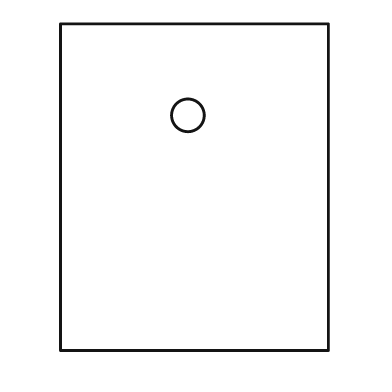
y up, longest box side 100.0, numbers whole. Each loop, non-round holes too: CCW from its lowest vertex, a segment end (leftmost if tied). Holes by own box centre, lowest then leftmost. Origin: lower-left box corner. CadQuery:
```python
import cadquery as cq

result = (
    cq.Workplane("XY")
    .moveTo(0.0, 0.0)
    .lineTo(82.0, 0.0)
    .lineTo(82.0, 100.0)
    .lineTo(0.0, 100.0)
    .close()
    .moveTo(39.0, 72.0)
    .circle(5.0)
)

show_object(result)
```